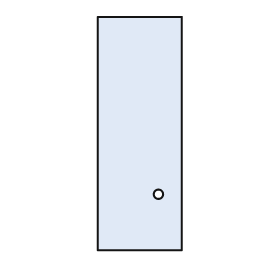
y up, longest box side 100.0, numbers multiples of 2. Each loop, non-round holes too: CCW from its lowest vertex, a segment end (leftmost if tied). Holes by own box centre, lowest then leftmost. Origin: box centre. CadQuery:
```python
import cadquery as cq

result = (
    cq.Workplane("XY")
    .moveTo(-18.0, -50.0)
    .lineTo(18.0, -50.0)
    .lineTo(18.0, 50.0)
    .lineTo(-18.0, 50.0)
    .close()
    .moveTo(8.0, -26.0)
    .circle(2.0)
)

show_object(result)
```